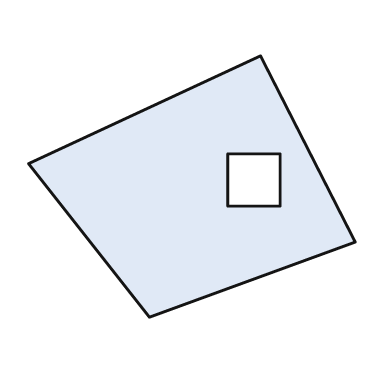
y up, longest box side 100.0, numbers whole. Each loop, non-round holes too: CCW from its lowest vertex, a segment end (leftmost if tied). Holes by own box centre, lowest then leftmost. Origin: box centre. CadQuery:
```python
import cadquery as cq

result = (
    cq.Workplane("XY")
    .moveTo(-13.0, -40.0)
    .lineTo(50.0, -17.0)
    .lineTo(21.0, 40.0)
    .lineTo(-50.0, 7.0)
    .close()
    .moveTo(11.0, -6.0)
    .lineTo(27.0, -6.0)
    .lineTo(27.0, 10.0)
    .lineTo(11.0, 10.0)
    .close()
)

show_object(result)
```